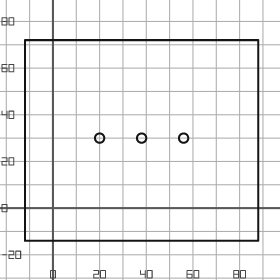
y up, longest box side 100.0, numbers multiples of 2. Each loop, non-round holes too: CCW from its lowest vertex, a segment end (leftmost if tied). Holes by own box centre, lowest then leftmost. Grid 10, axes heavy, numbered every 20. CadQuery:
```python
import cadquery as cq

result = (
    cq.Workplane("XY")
    .moveTo(-12.0, -14.0)
    .lineTo(88.0, -14.0)
    .lineTo(88.0, 72.0)
    .lineTo(-12.0, 72.0)
    .close()
    .moveTo(20.0, 30.0)
    .circle(2.0)
    .moveTo(38.0, 30.0)
    .circle(2.0)
    .moveTo(56.0, 30.0)
    .circle(2.0)
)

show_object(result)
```